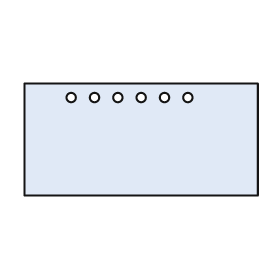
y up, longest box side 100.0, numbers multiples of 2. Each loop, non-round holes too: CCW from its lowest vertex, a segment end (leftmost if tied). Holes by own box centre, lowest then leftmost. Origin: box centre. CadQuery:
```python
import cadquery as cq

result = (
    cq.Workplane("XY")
    .moveTo(-50.0, -24.0)
    .lineTo(50.0, -24.0)
    .lineTo(50.0, 24.0)
    .lineTo(-50.0, 24.0)
    .close()
    .moveTo(-30.0, 18.0)
    .circle(2.0)
    .moveTo(-20.0, 18.0)
    .circle(2.0)
    .moveTo(-10.0, 18.0)
    .circle(2.0)
    .moveTo(0.0, 18.0)
    .circle(2.0)
    .moveTo(10.0, 18.0)
    .circle(2.0)
    .moveTo(20.0, 18.0)
    .circle(2.0)
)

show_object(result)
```